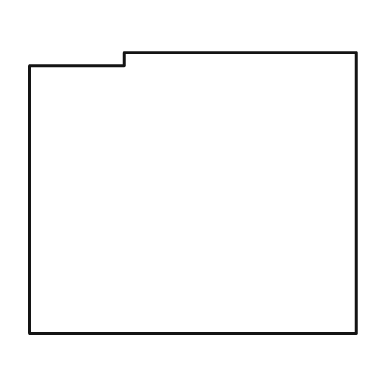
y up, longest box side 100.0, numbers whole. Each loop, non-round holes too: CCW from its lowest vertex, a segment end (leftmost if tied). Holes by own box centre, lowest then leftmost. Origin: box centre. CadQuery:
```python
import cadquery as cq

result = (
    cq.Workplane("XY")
    .moveTo(-50.0, -43.0)
    .lineTo(50.0, -43.0)
    .lineTo(50.0, 43.0)
    .lineTo(-21.0, 43.0)
    .lineTo(-21.0, 39.0)
    .lineTo(-50.0, 39.0)
    .close()
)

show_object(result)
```